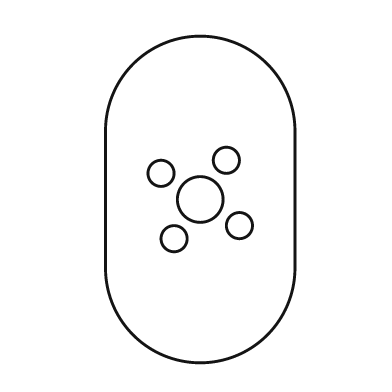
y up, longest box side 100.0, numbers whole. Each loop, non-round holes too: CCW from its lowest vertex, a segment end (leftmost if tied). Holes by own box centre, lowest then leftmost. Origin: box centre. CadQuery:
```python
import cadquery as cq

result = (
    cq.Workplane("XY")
    .moveTo(-29.0, -21.0)
    .threePointArc((0.0, -50.0), (29.0, -21.0))
    .lineTo(29.0, 21.0)
    .threePointArc((0.0, 50.0), (-29.0, 21.0))
    .close()
    .moveTo(-8.0, -12.0)
    .circle(4.0)
    .moveTo(12.0, -8.0)
    .circle(4.0)
    .moveTo(0.0, 0.0)
    .circle(7.0)
    .moveTo(-12.0, 8.0)
    .circle(4.0)
    .moveTo(8.0, 12.0)
    .circle(4.0)
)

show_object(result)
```